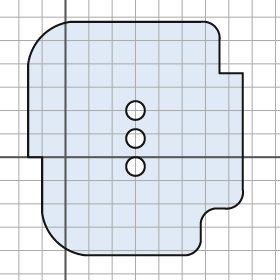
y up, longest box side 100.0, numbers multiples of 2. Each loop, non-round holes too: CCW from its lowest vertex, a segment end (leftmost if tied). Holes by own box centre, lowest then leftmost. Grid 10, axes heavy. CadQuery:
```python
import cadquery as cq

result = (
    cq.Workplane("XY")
    .moveTo(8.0, -42.0)
    .lineTo(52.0, -42.0)
    .threePointArc((56.0, -40.0), (58.0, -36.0))
    .lineTo(58.0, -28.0)
    .threePointArc((60.0, -24.0), (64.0, -22.0))
    .lineTo(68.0, -22.0)
    .threePointArc((74.0, -20.0), (76.0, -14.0))
    .lineTo(76.0, 36.0)
    .lineTo(66.0, 36.0)
    .lineTo(66.0, 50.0)
    .threePointArc((64.0, 56.0), (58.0, 58.0))
    .lineTo(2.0, 58.0)
    .threePointArc((-10.0, 52.0), (-16.0, 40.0))
    .lineTo(-16.0, 0.0)
    .lineTo(-10.0, 0.0)
    .lineTo(-10.0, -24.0)
    .threePointArc((-4.0, -36.0), (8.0, -42.0))
    .close()
    .moveTo(30.0, -4.0)
    .circle(4.0)
    .moveTo(30.0, 8.0)
    .circle(4.0)
    .moveTo(30.0, 20.0)
    .circle(4.0)
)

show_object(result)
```